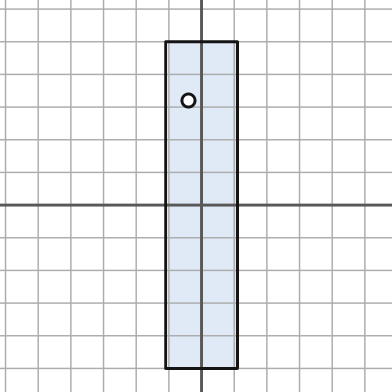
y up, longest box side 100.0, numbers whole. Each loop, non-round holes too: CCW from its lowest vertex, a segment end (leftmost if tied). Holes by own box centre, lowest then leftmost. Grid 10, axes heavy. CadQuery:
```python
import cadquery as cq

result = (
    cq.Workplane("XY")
    .moveTo(-11.0, -50.0)
    .lineTo(11.0, -50.0)
    .lineTo(11.0, 50.0)
    .lineTo(-11.0, 50.0)
    .close()
    .moveTo(-4.0, 32.0)
    .circle(2.0)
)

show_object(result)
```